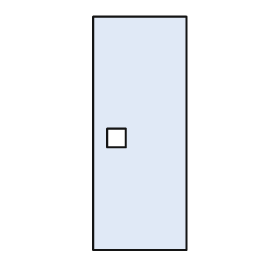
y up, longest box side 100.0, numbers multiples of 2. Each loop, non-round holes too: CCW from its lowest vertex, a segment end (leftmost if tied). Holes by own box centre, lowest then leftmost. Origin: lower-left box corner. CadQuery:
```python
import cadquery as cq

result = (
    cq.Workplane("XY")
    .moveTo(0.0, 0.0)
    .lineTo(40.0, 0.0)
    .lineTo(40.0, 100.0)
    .lineTo(0.0, 100.0)
    .close()
    .moveTo(6.0, 44.0)
    .lineTo(14.0, 44.0)
    .lineTo(14.0, 52.0)
    .lineTo(6.0, 52.0)
    .close()
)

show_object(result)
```